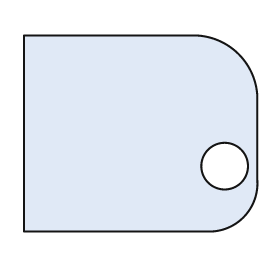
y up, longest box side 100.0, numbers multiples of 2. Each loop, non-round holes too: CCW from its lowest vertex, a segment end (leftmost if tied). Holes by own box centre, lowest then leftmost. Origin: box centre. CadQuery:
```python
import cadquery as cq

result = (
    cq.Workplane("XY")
    .moveTo(-50.0, -42.0)
    .lineTo(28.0, -42.0)
    .threePointArc((44.0, -36.0), (50.0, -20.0))
    .lineTo(50.0, 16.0)
    .threePointArc((42.0, 34.0), (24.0, 42.0))
    .lineTo(-50.0, 42.0)
    .close()
    .moveTo(36.0, -14.0)
    .circle(10.0)
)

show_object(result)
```